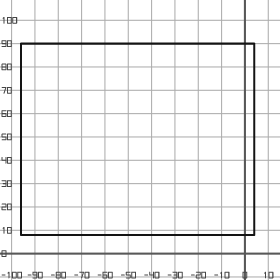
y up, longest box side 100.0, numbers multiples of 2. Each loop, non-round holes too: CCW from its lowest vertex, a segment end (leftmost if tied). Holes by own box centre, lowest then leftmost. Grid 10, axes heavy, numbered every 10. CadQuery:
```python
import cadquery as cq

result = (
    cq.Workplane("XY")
    .moveTo(-96.0, 8.0)
    .lineTo(4.0, 8.0)
    .lineTo(4.0, 90.0)
    .lineTo(-96.0, 90.0)
    .close()
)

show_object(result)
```